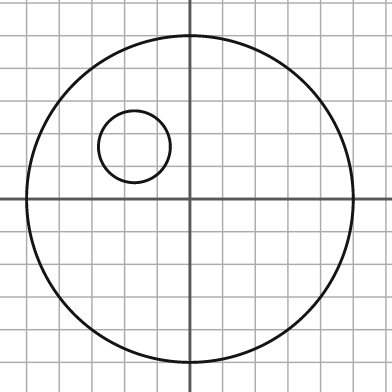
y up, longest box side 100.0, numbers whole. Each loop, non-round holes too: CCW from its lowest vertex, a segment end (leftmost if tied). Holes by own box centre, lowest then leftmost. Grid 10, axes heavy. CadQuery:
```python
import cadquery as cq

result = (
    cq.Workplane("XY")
    .moveTo(0.0, 0.0)
    .circle(50.0)
    .moveTo(-17.0, 16.0)
    .circle(11.0)
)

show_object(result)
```